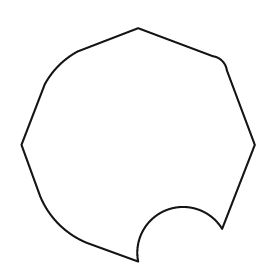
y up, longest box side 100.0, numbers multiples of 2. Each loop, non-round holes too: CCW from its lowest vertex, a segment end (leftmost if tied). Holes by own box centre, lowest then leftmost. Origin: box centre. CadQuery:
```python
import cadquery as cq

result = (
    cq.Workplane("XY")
    .moveTo(0.0, -50.0)
    .threePointArc((12.0, -28.0), (36.0, -36.0))
    .lineTo(50.0, 0.0)
    .lineTo(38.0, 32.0)
    .threePointArc((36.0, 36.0), (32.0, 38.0))
    .lineTo(0.0, 50.0)
    .lineTo(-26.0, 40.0)
    .threePointArc((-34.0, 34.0), (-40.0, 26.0))
    .lineTo(-50.0, 0.0)
    .lineTo(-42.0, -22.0)
    .threePointArc((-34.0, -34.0), (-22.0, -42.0))
    .close()
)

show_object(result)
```